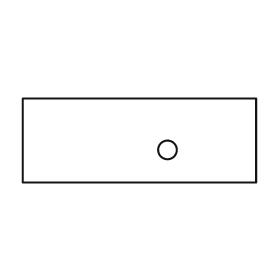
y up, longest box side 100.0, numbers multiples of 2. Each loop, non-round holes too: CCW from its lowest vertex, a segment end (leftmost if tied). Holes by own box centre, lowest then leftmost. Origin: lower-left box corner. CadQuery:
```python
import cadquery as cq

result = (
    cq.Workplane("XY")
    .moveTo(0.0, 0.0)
    .lineTo(100.0, 0.0)
    .lineTo(100.0, 36.0)
    .lineTo(0.0, 36.0)
    .close()
    .moveTo(62.0, 14.0)
    .circle(4.0)
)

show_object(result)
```